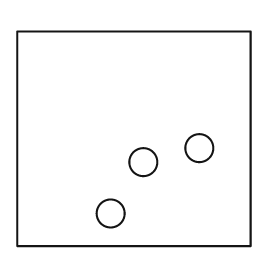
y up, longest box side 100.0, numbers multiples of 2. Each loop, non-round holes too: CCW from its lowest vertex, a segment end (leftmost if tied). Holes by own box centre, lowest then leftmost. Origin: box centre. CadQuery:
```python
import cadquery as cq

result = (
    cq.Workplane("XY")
    .moveTo(-50.0, -46.0)
    .lineTo(50.0, -46.0)
    .lineTo(50.0, 46.0)
    .lineTo(-50.0, 46.0)
    .close()
    .moveTo(-10.0, -32.0)
    .circle(6.0)
    .moveTo(4.0, -10.0)
    .circle(6.0)
    .moveTo(28.0, -4.0)
    .circle(6.0)
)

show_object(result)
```